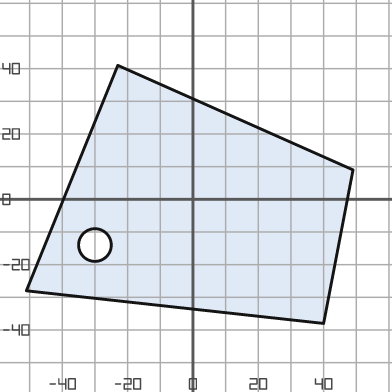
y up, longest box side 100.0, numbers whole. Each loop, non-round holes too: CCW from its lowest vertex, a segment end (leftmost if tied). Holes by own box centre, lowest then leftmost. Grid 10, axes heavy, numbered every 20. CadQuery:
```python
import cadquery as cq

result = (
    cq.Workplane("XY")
    .moveTo(40.0, -38.0)
    .lineTo(49.0, 9.0)
    .lineTo(-23.0, 41.0)
    .lineTo(-51.0, -28.0)
    .close()
    .moveTo(-30.0, -14.0)
    .circle(5.0)
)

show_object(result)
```